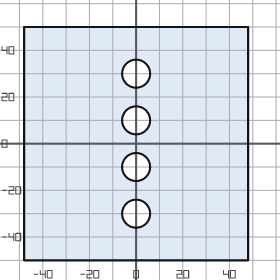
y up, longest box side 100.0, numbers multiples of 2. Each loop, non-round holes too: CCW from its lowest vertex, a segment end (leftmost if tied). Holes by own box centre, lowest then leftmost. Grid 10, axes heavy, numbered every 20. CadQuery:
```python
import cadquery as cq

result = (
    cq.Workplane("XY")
    .moveTo(-48.0, -50.0)
    .lineTo(48.0, -50.0)
    .lineTo(48.0, 50.0)
    .lineTo(-48.0, 50.0)
    .close()
    .moveTo(0.0, -30.0)
    .circle(6.0)
    .moveTo(0.0, -10.0)
    .circle(6.0)
    .moveTo(0.0, 10.0)
    .circle(6.0)
    .moveTo(0.0, 30.0)
    .circle(6.0)
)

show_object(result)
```